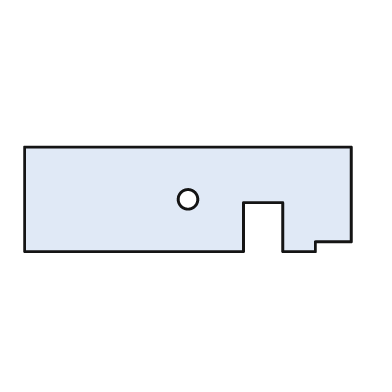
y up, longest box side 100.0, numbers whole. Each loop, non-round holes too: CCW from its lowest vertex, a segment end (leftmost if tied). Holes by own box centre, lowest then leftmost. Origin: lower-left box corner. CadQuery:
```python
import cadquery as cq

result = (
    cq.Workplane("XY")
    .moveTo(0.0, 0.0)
    .lineTo(67.0, 0.0)
    .lineTo(67.0, 15.0)
    .lineTo(79.0, 15.0)
    .lineTo(79.0, 0.0)
    .lineTo(89.0, 0.0)
    .lineTo(89.0, 3.0)
    .lineTo(100.0, 3.0)
    .lineTo(100.0, 32.0)
    .lineTo(0.0, 32.0)
    .close()
    .moveTo(50.0, 16.0)
    .circle(3.0)
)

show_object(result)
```